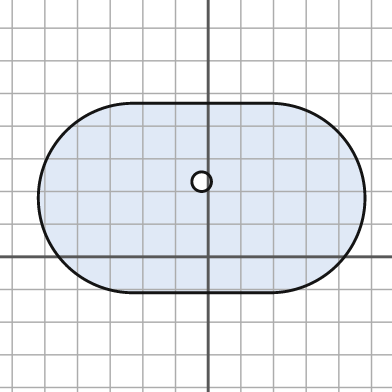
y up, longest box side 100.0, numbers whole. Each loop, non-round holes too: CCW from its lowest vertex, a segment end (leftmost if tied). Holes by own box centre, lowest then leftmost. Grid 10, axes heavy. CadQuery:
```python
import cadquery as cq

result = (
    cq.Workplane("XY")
    .moveTo(-23.0, -11.0)
    .lineTo(19.0, -11.0)
    .threePointArc((48.0, 18.0), (19.0, 47.0))
    .lineTo(-23.0, 47.0)
    .threePointArc((-52.0, 18.0), (-23.0, -11.0))
    .close()
    .moveTo(-2.0, 23.0)
    .circle(3.0)
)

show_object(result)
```